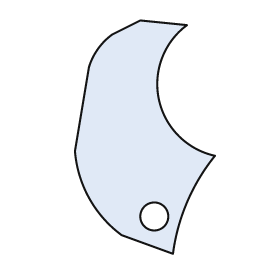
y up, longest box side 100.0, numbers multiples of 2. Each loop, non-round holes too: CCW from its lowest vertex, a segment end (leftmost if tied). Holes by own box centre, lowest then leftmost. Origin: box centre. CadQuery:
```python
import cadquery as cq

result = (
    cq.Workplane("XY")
    .moveTo(12.0, -50.0)
    .threePointArc((18.0, -28.0), (30.0, -8.0))
    .threePointArc((6.0, 16.0), (18.0, 48.0))
    .lineTo(-2.0, 50.0)
    .lineTo(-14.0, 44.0)
    .threePointArc((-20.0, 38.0), (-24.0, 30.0))
    .lineTo(-30.0, -6.0)
    .threePointArc((-24.0, -26.0), (-10.0, -42.0))
    .close()
    .moveTo(4.0, -34.0)
    .circle(6.0)
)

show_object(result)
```